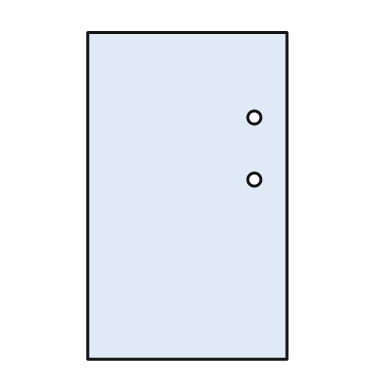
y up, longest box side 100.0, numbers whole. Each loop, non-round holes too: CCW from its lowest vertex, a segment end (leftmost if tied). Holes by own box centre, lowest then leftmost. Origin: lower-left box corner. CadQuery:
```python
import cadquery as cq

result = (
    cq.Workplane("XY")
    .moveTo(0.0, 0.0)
    .lineTo(61.0, 0.0)
    .lineTo(61.0, 100.0)
    .lineTo(0.0, 100.0)
    .close()
    .moveTo(51.0, 55.0)
    .circle(2.0)
    .moveTo(51.0, 74.0)
    .circle(2.0)
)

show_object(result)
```